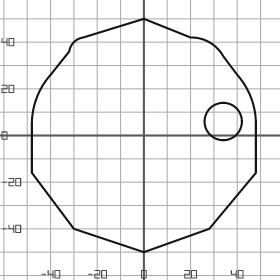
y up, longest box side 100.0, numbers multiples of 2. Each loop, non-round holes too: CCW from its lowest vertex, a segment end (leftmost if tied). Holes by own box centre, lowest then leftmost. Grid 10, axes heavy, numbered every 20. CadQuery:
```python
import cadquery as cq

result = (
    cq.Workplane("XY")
    .moveTo(0.0, -50.0)
    .lineTo(28.0, -40.0)
    .lineTo(48.0, -16.0)
    .lineTo(48.0, 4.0)
    .threePointArc((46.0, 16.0), (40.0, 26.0))
    .lineTo(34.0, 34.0)
    .threePointArc((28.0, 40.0), (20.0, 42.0))
    .lineTo(0.0, 50.0)
    .lineTo(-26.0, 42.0)
    .threePointArc((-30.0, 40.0), (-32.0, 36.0))
    .lineTo(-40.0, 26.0)
    .threePointArc((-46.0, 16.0), (-48.0, 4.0))
    .lineTo(-48.0, -16.0)
    .lineTo(-30.0, -40.0)
    .close()
    .moveTo(34.0, 6.0)
    .circle(8.0)
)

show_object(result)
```